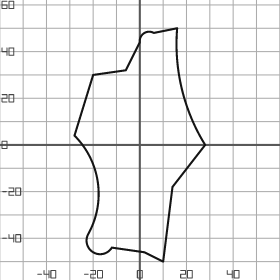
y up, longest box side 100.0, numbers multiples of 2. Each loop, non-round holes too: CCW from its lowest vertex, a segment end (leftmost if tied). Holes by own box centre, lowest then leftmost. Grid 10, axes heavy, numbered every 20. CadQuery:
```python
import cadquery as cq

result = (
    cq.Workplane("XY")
    .moveTo(10.0, -50.0)
    .lineTo(14.0, -18.0)
    .lineTo(28.0, 0.0)
    .threePointArc((18.0, 24.0), (16.0, 50.0))
    .lineTo(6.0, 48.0)
    .threePointArc((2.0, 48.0), (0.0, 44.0))
    .lineTo(-6.0, 32.0)
    .lineTo(-20.0, 30.0)
    .lineTo(-28.0, 4.0)
    .threePointArc((-18.0, -16.0), (-22.0, -38.0))
    .threePointArc((-20.0, -46.0), (-12.0, -44.0))
    .lineTo(2.0, -46.0)
    .close()
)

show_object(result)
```